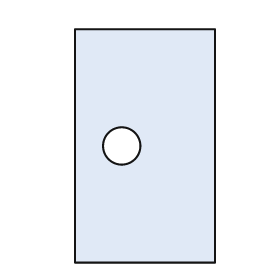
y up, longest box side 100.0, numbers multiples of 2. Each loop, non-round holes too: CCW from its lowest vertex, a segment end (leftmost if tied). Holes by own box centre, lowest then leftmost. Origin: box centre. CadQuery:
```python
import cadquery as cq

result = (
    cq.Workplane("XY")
    .moveTo(-30.0, -50.0)
    .lineTo(30.0, -50.0)
    .lineTo(30.0, 50.0)
    .lineTo(-30.0, 50.0)
    .close()
    .moveTo(-10.0, 0.0)
    .circle(8.0)
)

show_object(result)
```